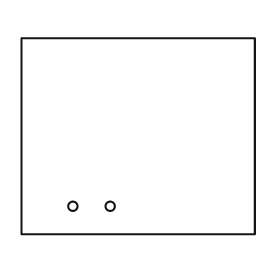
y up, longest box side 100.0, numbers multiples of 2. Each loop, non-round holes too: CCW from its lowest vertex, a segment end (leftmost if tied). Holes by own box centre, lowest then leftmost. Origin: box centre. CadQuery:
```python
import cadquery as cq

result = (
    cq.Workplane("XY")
    .moveTo(-50.0, -42.0)
    .lineTo(50.0, -42.0)
    .lineTo(50.0, 42.0)
    .lineTo(-50.0, 42.0)
    .close()
    .moveTo(-28.0, -30.0)
    .circle(2.0)
    .moveTo(-12.0, -30.0)
    .circle(2.0)
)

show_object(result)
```